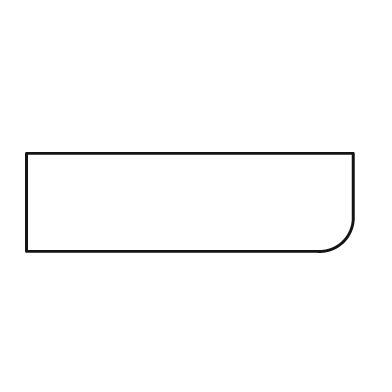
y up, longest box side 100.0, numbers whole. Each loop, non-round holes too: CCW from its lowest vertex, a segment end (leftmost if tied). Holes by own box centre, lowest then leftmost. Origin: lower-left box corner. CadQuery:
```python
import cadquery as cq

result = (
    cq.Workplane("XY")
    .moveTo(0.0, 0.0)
    .lineTo(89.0, 0.0)
    .threePointArc((97.0, 3.0), (100.0, 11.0))
    .lineTo(100.0, 30.0)
    .lineTo(0.0, 30.0)
    .close()
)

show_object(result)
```